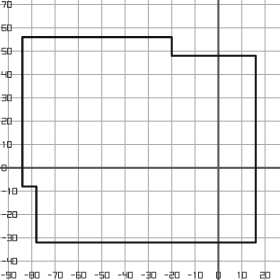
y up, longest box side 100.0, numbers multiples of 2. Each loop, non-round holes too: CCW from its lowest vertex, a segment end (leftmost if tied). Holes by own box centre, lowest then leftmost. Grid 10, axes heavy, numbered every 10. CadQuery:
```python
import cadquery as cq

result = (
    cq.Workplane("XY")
    .moveTo(-78.0, -32.0)
    .lineTo(16.0, -32.0)
    .lineTo(16.0, 48.0)
    .lineTo(-20.0, 48.0)
    .lineTo(-20.0, 56.0)
    .lineTo(-84.0, 56.0)
    .lineTo(-84.0, -8.0)
    .lineTo(-78.0, -8.0)
    .close()
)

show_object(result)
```